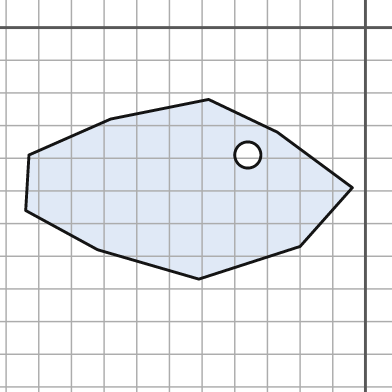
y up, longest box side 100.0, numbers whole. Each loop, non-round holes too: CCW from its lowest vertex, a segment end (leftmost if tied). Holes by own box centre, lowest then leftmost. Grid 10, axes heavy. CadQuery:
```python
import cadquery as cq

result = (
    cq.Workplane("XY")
    .moveTo(-51.0, -77.0)
    .lineTo(-20.0, -67.0)
    .lineTo(-4.0, -49.0)
    .lineTo(-27.0, -32.0)
    .lineTo(-48.0, -22.0)
    .lineTo(-78.0, -28.0)
    .lineTo(-103.0, -39.0)
    .lineTo(-104.0, -56.0)
    .lineTo(-82.0, -68.0)
    .close()
    .moveTo(-36.0, -39.0)
    .circle(4.0)
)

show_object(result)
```